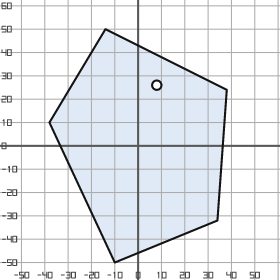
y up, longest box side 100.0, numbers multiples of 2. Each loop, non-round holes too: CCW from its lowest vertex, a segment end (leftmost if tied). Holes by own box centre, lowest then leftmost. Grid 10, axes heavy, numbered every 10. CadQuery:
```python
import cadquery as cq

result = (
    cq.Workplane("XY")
    .moveTo(-10.0, -50.0)
    .lineTo(34.0, -32.0)
    .lineTo(38.0, 24.0)
    .lineTo(-14.0, 50.0)
    .lineTo(-38.0, 10.0)
    .close()
    .moveTo(8.0, 26.0)
    .circle(2.0)
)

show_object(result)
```